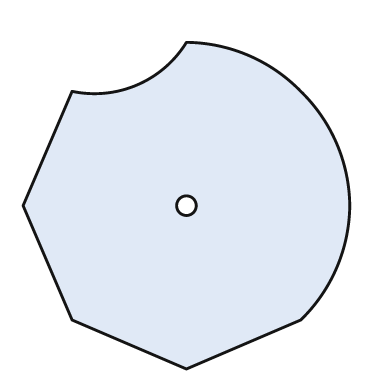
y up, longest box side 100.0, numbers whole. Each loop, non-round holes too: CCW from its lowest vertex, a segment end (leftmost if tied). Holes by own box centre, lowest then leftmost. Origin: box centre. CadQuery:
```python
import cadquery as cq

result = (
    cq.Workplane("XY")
    .moveTo(0.0, -50.0)
    .lineTo(35.0, -35.0)
    .threePointArc((46.0, -19.0), (50.0, 0.0))
    .threePointArc((46.0, 19.0), (35.0, 35.0))
    .threePointArc((19.0, 46.0), (0.0, 50.0))
    .threePointArc((-15.0, 37.0), (-35.0, 35.0))
    .lineTo(-50.0, 0.0)
    .lineTo(-35.0, -35.0)
    .close()
    .moveTo(0.0, 0.0)
    .circle(3.0)
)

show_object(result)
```